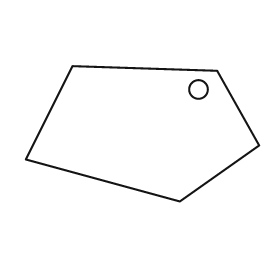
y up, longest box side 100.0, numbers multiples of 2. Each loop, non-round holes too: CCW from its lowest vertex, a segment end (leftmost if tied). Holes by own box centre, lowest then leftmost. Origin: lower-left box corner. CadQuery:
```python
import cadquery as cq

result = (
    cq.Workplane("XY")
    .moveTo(66.0, 0.0)
    .lineTo(100.0, 24.0)
    .lineTo(82.0, 56.0)
    .lineTo(20.0, 58.0)
    .lineTo(0.0, 18.0)
    .close()
    .moveTo(74.0, 48.0)
    .circle(4.0)
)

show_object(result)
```